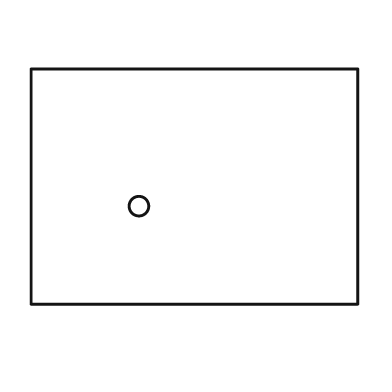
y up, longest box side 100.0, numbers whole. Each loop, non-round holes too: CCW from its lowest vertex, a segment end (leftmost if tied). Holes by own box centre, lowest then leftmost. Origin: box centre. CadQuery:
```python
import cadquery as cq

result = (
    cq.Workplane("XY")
    .moveTo(-50.0, -36.0)
    .lineTo(50.0, -36.0)
    .lineTo(50.0, 36.0)
    .lineTo(-50.0, 36.0)
    .close()
    .moveTo(-17.0, -6.0)
    .circle(3.0)
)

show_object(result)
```